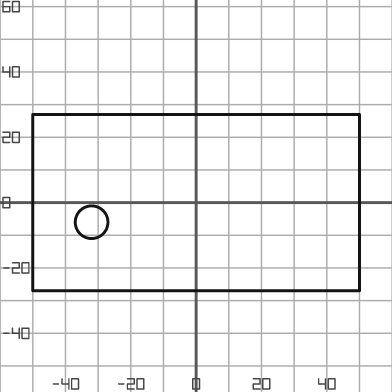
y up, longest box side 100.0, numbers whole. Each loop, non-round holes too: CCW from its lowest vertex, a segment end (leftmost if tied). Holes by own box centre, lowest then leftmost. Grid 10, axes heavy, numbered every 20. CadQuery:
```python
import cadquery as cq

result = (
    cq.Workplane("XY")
    .moveTo(-50.0, -27.0)
    .lineTo(50.0, -27.0)
    .lineTo(50.0, 27.0)
    .lineTo(-50.0, 27.0)
    .close()
    .moveTo(-32.0, -6.0)
    .circle(5.0)
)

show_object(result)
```